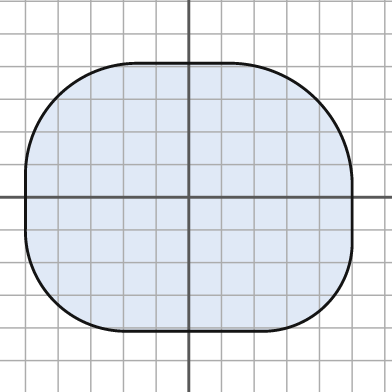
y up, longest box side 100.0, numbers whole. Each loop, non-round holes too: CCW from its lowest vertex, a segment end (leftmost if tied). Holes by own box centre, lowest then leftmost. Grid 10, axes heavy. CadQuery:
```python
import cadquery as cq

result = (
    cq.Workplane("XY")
    .moveTo(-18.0, -41.0)
    .lineTo(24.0, -41.0)
    .threePointArc((42.0, -33.0), (50.0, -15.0))
    .lineTo(50.0, 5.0)
    .threePointArc((39.0, 30.0), (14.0, 41.0))
    .lineTo(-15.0, 41.0)
    .threePointArc((-40.0, 31.0), (-50.0, 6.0))
    .lineTo(-50.0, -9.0)
    .threePointArc((-41.0, -32.0), (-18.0, -41.0))
    .close()
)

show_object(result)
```